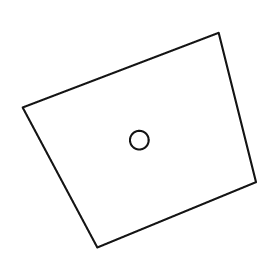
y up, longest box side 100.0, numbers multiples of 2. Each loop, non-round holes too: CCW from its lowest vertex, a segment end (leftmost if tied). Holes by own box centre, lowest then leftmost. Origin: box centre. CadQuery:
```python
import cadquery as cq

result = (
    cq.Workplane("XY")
    .moveTo(-18.0, -46.0)
    .lineTo(50.0, -18.0)
    .lineTo(34.0, 46.0)
    .lineTo(-50.0, 14.0)
    .close()
    .moveTo(0.0, 0.0)
    .circle(4.0)
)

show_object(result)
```